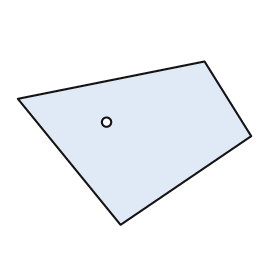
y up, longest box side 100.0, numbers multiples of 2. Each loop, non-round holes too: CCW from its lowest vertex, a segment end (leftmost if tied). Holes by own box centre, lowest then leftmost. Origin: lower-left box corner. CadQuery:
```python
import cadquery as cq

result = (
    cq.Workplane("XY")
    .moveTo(44.0, 0.0)
    .lineTo(100.0, 38.0)
    .lineTo(80.0, 70.0)
    .lineTo(0.0, 54.0)
    .close()
    .moveTo(38.0, 44.0)
    .circle(2.0)
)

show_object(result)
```